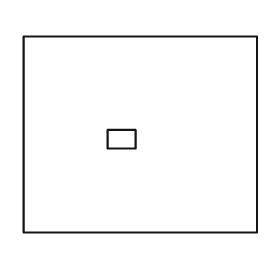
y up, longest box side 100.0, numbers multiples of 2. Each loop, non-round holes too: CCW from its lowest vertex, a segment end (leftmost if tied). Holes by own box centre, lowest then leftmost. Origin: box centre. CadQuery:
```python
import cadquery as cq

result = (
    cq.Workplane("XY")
    .moveTo(-50.0, -42.0)
    .lineTo(50.0, -42.0)
    .lineTo(50.0, 42.0)
    .lineTo(-50.0, 42.0)
    .close()
    .moveTo(-14.0, -6.0)
    .lineTo(-2.0, -6.0)
    .lineTo(-2.0, 2.0)
    .lineTo(-14.0, 2.0)
    .close()
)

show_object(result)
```